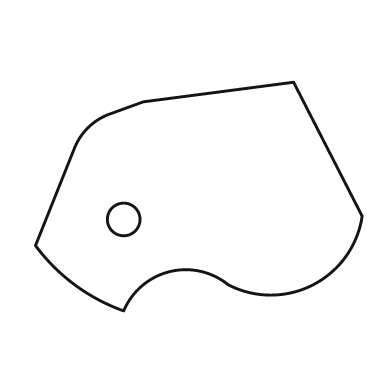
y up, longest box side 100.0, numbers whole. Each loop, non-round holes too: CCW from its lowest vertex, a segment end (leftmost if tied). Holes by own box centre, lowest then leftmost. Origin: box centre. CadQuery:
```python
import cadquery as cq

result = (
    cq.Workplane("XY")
    .moveTo(-23.0, -35.0)
    .threePointArc((-9.0, -23.0), (9.0, -27.0))
    .threePointArc((35.0, -27.0), (50.0, -6.0))
    .lineTo(29.0, 35.0)
    .lineTo(-17.0, 29.0)
    .lineTo(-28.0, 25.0)
    .threePointArc((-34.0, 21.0), (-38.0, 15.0))
    .lineTo(-50.0, -15.0)
    .threePointArc((-38.0, -27.0), (-23.0, -35.0))
    .close()
    .moveTo(-23.0, -7.0)
    .circle(5.0)
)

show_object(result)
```